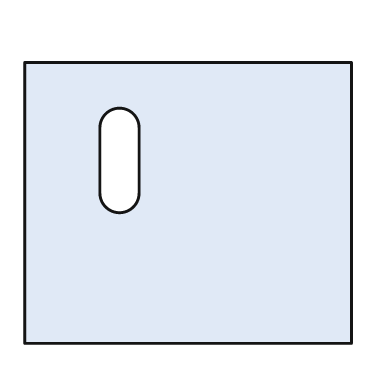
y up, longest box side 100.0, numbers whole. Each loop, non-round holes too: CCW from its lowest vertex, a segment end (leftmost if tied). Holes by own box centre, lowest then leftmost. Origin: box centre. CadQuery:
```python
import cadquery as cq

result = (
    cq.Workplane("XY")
    .moveTo(-50.0, -43.0)
    .lineTo(50.0, -43.0)
    .lineTo(50.0, 43.0)
    .lineTo(-50.0, 43.0)
    .close()
    .moveTo(-27.0, 3.0)
    .threePointArc((-21.0, -3.0), (-15.0, 3.0))
    .lineTo(-15.0, 23.0)
    .threePointArc((-21.0, 29.0), (-27.0, 23.0))
    .close()
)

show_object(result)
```